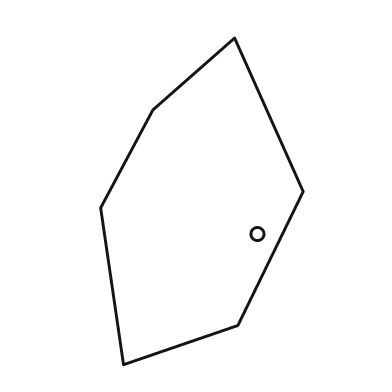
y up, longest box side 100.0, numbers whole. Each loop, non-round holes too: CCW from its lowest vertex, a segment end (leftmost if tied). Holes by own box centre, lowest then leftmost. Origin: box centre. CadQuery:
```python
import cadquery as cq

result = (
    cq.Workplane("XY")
    .moveTo(-24.0, -50.0)
    .lineTo(11.0, -38.0)
    .lineTo(31.0, 3.0)
    .lineTo(10.0, 50.0)
    .lineTo(-15.0, 28.0)
    .lineTo(-31.0, -2.0)
    .close()
    .moveTo(17.0, -10.0)
    .circle(2.0)
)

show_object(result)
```